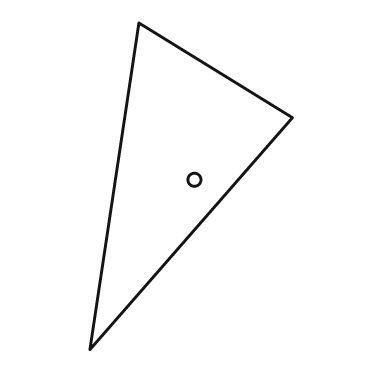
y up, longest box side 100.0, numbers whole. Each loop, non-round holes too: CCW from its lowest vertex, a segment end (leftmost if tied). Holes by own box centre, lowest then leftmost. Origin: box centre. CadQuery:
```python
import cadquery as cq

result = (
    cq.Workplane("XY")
    .moveTo(-31.0, -50.0)
    .lineTo(31.0, 21.0)
    .lineTo(-16.0, 50.0)
    .close()
    .moveTo(1.0, 2.0)
    .circle(2.0)
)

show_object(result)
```